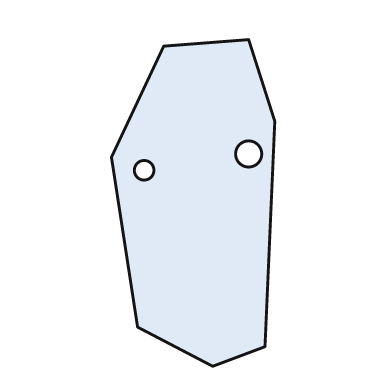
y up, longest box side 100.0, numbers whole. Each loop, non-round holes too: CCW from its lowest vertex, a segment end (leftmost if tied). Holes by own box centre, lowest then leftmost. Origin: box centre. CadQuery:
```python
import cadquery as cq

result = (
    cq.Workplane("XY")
    .moveTo(6.0, -50.0)
    .lineTo(22.0, -44.0)
    .lineTo(25.0, 25.0)
    .lineTo(17.0, 50.0)
    .lineTo(-9.0, 48.0)
    .lineTo(-25.0, 14.0)
    .lineTo(-17.0, -38.0)
    .close()
    .moveTo(-15.0, 10.0)
    .circle(3.0)
    .moveTo(17.0, 15.0)
    .circle(4.0)
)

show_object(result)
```